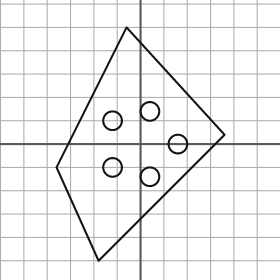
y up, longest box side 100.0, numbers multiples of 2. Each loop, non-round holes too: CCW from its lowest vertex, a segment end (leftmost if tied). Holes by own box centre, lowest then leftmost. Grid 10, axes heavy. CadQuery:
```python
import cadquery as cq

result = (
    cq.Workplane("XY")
    .moveTo(-18.0, -50.0)
    .lineTo(36.0, 4.0)
    .lineTo(-6.0, 50.0)
    .lineTo(-36.0, -10.0)
    .close()
    .moveTo(4.0, -14.0)
    .circle(4.0)
    .moveTo(-12.0, -10.0)
    .circle(4.0)
    .moveTo(16.0, 0.0)
    .circle(4.0)
    .moveTo(-12.0, 10.0)
    .circle(4.0)
    .moveTo(4.0, 14.0)
    .circle(4.0)
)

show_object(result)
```